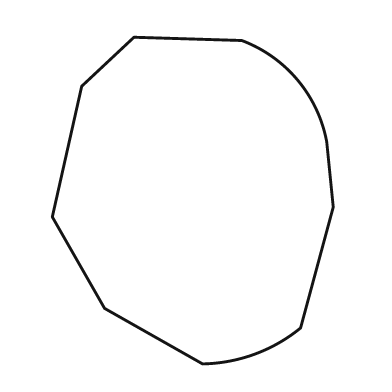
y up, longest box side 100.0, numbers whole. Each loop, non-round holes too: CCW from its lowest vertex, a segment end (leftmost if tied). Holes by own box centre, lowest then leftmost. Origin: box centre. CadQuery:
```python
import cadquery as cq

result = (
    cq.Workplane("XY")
    .moveTo(3.0, -50.0)
    .threePointArc((19.0, -47.0), (33.0, -39.0))
    .lineTo(43.0, -2.0)
    .lineTo(41.0, 18.0)
    .threePointArc((32.0, 37.0), (15.0, 49.0))
    .lineTo(-18.0, 50.0)
    .lineTo(-34.0, 35.0)
    .lineTo(-43.0, -5.0)
    .lineTo(-27.0, -33.0)
    .close()
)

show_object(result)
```